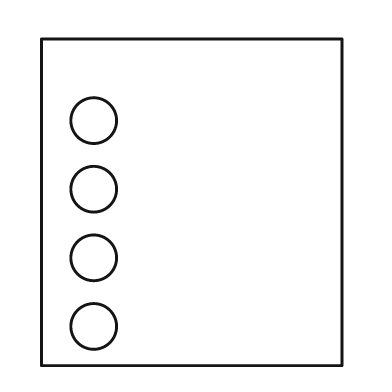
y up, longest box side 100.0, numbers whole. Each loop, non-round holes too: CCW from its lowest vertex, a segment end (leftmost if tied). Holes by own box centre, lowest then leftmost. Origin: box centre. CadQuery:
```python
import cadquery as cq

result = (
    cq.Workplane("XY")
    .moveTo(-46.0, -50.0)
    .lineTo(46.0, -50.0)
    .lineTo(46.0, 50.0)
    .lineTo(-46.0, 50.0)
    .close()
    .moveTo(-30.0, -38.0)
    .circle(7.0)
    .moveTo(-30.0, -17.0)
    .circle(7.0)
    .moveTo(-30.0, 4.0)
    .circle(7.0)
    .moveTo(-30.0, 25.0)
    .circle(7.0)
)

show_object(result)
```